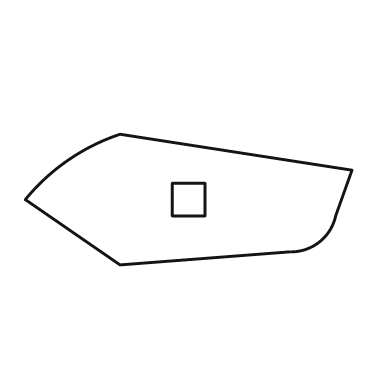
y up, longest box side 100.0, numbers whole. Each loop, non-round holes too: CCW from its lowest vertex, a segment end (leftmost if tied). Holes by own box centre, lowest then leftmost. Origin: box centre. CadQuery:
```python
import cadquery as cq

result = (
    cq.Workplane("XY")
    .moveTo(-21.0, -20.0)
    .lineTo(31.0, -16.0)
    .threePointArc((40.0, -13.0), (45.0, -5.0))
    .lineTo(50.0, 9.0)
    .lineTo(-21.0, 20.0)
    .threePointArc((-37.0, 12.0), (-50.0, 0.0))
    .close()
    .moveTo(-5.0, -5.0)
    .lineTo(5.0, -5.0)
    .lineTo(5.0, 5.0)
    .lineTo(-5.0, 5.0)
    .close()
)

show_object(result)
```